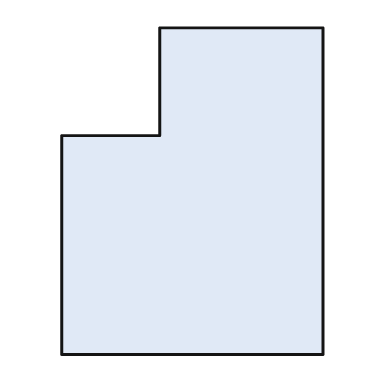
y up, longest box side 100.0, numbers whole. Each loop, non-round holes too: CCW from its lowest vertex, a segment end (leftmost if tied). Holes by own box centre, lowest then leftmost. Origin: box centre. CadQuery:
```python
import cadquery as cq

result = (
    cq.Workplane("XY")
    .moveTo(-40.0, -50.0)
    .lineTo(40.0, -50.0)
    .lineTo(40.0, 50.0)
    .lineTo(-10.0, 50.0)
    .lineTo(-10.0, 17.0)
    .lineTo(-40.0, 17.0)
    .close()
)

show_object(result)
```